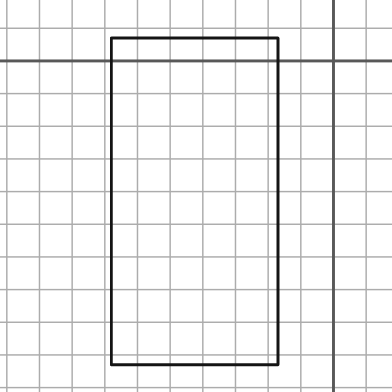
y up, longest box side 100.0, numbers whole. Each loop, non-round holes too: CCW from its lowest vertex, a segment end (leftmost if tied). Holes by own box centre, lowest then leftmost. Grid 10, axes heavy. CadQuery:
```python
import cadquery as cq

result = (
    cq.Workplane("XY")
    .moveTo(-68.0, -93.0)
    .lineTo(-17.0, -93.0)
    .lineTo(-17.0, 7.0)
    .lineTo(-68.0, 7.0)
    .close()
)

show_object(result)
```